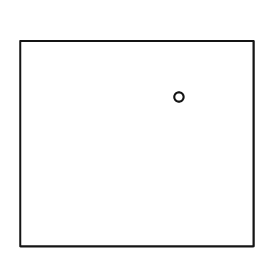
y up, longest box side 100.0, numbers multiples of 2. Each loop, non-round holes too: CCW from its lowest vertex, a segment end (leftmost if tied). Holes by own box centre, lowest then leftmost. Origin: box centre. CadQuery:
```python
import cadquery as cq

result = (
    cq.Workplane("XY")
    .moveTo(-50.0, -44.0)
    .lineTo(50.0, -44.0)
    .lineTo(50.0, 44.0)
    .lineTo(-50.0, 44.0)
    .close()
    .moveTo(18.0, 20.0)
    .circle(2.0)
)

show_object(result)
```